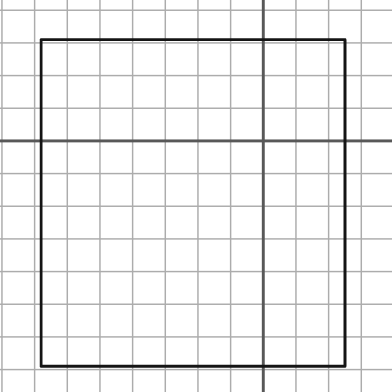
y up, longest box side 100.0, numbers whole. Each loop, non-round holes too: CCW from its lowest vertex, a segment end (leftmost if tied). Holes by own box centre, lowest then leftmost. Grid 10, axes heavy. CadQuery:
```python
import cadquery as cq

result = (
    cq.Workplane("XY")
    .moveTo(-68.0, -69.0)
    .lineTo(25.0, -69.0)
    .lineTo(25.0, 31.0)
    .lineTo(-68.0, 31.0)
    .close()
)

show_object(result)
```